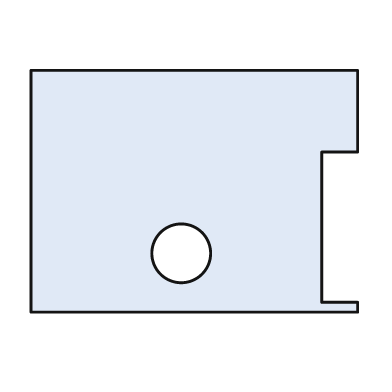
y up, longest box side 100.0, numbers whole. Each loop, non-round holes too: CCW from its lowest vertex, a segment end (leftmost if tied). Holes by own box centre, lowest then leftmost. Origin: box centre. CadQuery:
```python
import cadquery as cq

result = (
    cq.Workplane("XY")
    .moveTo(-50.0, -37.0)
    .lineTo(50.0, -37.0)
    .lineTo(50.0, -34.0)
    .lineTo(39.0, -34.0)
    .lineTo(39.0, 12.0)
    .lineTo(50.0, 12.0)
    .lineTo(50.0, 37.0)
    .lineTo(-50.0, 37.0)
    .close()
    .moveTo(-4.0, -19.0)
    .circle(9.0)
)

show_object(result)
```